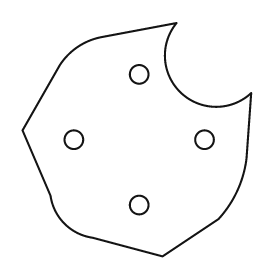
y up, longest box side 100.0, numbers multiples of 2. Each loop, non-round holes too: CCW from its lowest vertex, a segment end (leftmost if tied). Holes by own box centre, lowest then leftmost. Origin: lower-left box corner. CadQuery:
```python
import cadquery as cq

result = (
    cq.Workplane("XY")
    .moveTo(60.0, 0.0)
    .lineTo(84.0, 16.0)
    .threePointArc((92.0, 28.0), (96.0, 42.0))
    .lineTo(98.0, 70.0)
    .threePointArc((68.0, 70.0), (66.0, 100.0))
    .lineTo(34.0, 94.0)
    .threePointArc((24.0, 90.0), (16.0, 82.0))
    .lineTo(0.0, 54.0)
    .lineTo(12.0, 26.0)
    .threePointArc((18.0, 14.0), (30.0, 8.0))
    .close()
    .moveTo(50.0, 22.0)
    .circle(4.0)
    .moveTo(22.0, 50.0)
    .circle(4.0)
    .moveTo(78.0, 50.0)
    .circle(4.0)
    .moveTo(50.0, 78.0)
    .circle(4.0)
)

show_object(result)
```